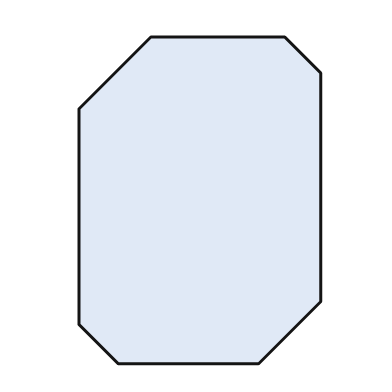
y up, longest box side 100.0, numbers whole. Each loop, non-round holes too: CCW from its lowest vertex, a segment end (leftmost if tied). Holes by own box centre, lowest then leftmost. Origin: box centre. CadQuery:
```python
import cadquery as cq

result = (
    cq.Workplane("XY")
    .moveTo(-25.0, -50.0)
    .lineTo(18.0, -50.0)
    .lineTo(37.0, -31.0)
    .lineTo(37.0, 39.0)
    .lineTo(26.0, 50.0)
    .lineTo(-15.0, 50.0)
    .lineTo(-37.0, 28.0)
    .lineTo(-37.0, -38.0)
    .close()
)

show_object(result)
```